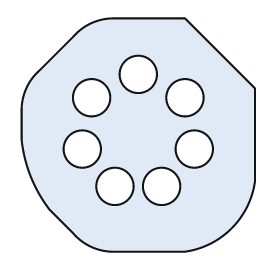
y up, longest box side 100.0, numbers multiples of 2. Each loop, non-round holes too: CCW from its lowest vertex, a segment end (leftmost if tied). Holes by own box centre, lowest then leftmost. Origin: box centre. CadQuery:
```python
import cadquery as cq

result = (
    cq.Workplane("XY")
    .moveTo(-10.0, -50.0)
    .lineTo(20.0, -50.0)
    .threePointArc((40.0, -40.0), (50.0, -20.0))
    .lineTo(50.0, 20.0)
    .lineTo(20.0, 50.0)
    .lineTo(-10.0, 50.0)
    .threePointArc((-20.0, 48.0), (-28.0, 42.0))
    .lineTo(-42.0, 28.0)
    .threePointArc((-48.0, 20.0), (-50.0, 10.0))
    .lineTo(-50.0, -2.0)
    .threePointArc((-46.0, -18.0), (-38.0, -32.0))
    .lineTo(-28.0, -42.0)
    .threePointArc((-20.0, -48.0), (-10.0, -50.0))
    .close()
    .moveTo(-10.0, -22.0)
    .circle(8.0)
    .moveTo(10.0, -22.0)
    .circle(8.0)
    .moveTo(-24.0, -6.0)
    .circle(8.0)
    .moveTo(24.0, -6.0)
    .circle(8.0)
    .moveTo(-20.0, 16.0)
    .circle(8.0)
    .moveTo(20.0, 16.0)
    .circle(8.0)
    .moveTo(0.0, 26.0)
    .circle(8.0)
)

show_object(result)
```